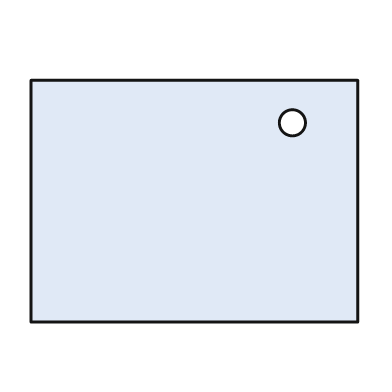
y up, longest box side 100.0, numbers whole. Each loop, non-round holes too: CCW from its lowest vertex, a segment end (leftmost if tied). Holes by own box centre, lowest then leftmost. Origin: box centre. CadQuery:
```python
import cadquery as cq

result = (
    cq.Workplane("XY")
    .moveTo(-50.0, -37.0)
    .lineTo(50.0, -37.0)
    .lineTo(50.0, 37.0)
    .lineTo(-50.0, 37.0)
    .close()
    .moveTo(30.0, 24.0)
    .circle(4.0)
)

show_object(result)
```